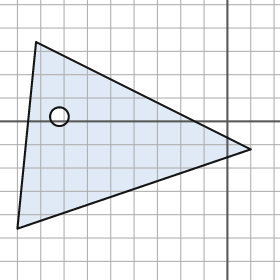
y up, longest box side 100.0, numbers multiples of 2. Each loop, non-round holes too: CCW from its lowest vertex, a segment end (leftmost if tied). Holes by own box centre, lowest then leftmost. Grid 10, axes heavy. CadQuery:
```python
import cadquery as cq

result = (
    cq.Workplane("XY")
    .moveTo(-90.0, -46.0)
    .lineTo(10.0, -12.0)
    .lineTo(-82.0, 34.0)
    .close()
    .moveTo(-72.0, 2.0)
    .circle(4.0)
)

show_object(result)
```